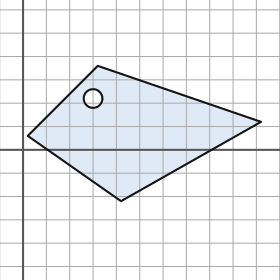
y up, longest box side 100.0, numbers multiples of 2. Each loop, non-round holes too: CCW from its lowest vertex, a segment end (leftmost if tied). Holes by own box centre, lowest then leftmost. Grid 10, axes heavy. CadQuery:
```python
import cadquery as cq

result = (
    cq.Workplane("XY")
    .moveTo(42.0, -22.0)
    .lineTo(102.0, 12.0)
    .lineTo(32.0, 36.0)
    .lineTo(2.0, 6.0)
    .close()
    .moveTo(30.0, 22.0)
    .circle(4.0)
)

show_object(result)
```